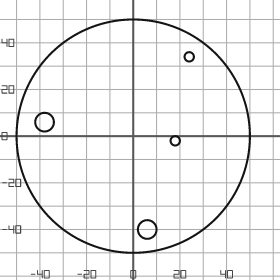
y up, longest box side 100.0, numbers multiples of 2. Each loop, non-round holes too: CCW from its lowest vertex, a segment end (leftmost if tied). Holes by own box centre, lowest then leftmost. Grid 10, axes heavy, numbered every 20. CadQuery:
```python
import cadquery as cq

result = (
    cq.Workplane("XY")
    .moveTo(0.0, 0.0)
    .circle(50.0)
    .moveTo(6.0, -40.0)
    .circle(4.0)
    .moveTo(18.0, -2.0)
    .circle(2.0)
    .moveTo(-38.0, 6.0)
    .circle(4.0)
    .moveTo(24.0, 34.0)
    .circle(2.0)
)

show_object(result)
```